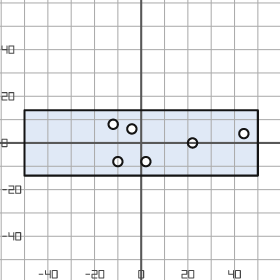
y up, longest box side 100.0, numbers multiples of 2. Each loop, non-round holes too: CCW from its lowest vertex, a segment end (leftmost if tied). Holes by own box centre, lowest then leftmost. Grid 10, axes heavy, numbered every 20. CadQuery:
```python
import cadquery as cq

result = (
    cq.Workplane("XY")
    .moveTo(-50.0, -14.0)
    .lineTo(50.0, -14.0)
    .lineTo(50.0, 14.0)
    .lineTo(-50.0, 14.0)
    .close()
    .moveTo(-10.0, -8.0)
    .circle(2.0)
    .moveTo(2.0, -8.0)
    .circle(2.0)
    .moveTo(22.0, 0.0)
    .circle(2.0)
    .moveTo(44.0, 4.0)
    .circle(2.0)
    .moveTo(-4.0, 6.0)
    .circle(2.0)
    .moveTo(-12.0, 8.0)
    .circle(2.0)
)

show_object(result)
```